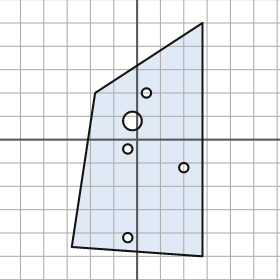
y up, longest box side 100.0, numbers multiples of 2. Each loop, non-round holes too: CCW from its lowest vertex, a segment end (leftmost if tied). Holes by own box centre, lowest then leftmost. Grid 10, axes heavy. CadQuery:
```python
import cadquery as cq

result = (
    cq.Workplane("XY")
    .moveTo(28.0, -50.0)
    .lineTo(28.0, 50.0)
    .lineTo(-18.0, 20.0)
    .lineTo(-28.0, -46.0)
    .close()
    .moveTo(-4.0, -42.0)
    .circle(2.0)
    .moveTo(20.0, -12.0)
    .circle(2.0)
    .moveTo(-4.0, -4.0)
    .circle(2.0)
    .moveTo(-2.0, 8.0)
    .circle(4.0)
    .moveTo(4.0, 20.0)
    .circle(2.0)
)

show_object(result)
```